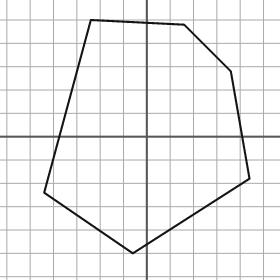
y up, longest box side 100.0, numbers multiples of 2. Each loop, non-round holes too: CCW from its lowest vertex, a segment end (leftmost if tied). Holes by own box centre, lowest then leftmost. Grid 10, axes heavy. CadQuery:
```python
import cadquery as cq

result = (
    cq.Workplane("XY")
    .moveTo(-6.0, -50.0)
    .lineTo(44.0, -18.0)
    .lineTo(36.0, 28.0)
    .lineTo(16.0, 48.0)
    .lineTo(-24.0, 50.0)
    .lineTo(-44.0, -24.0)
    .close()
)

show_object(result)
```